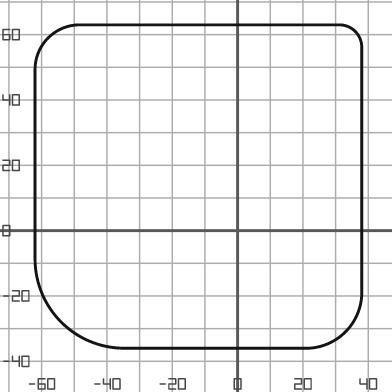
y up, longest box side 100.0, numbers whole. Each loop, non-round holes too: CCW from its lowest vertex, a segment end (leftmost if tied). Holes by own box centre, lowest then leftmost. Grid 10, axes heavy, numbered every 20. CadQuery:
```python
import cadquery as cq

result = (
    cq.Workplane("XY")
    .moveTo(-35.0, -36.0)
    .lineTo(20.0, -36.0)
    .threePointArc((33.0, -31.0), (38.0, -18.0))
    .lineTo(38.0, 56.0)
    .threePointArc((36.0, 61.0), (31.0, 63.0))
    .lineTo(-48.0, 63.0)
    .threePointArc((-58.0, 59.0), (-62.0, 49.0))
    .lineTo(-62.0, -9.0)
    .threePointArc((-54.0, -28.0), (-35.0, -36.0))
    .close()
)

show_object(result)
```